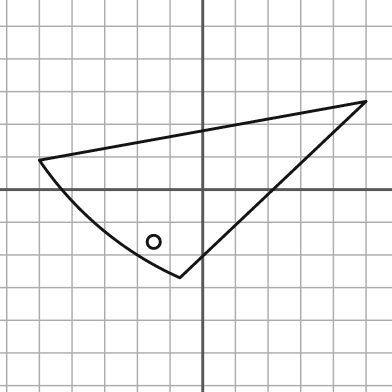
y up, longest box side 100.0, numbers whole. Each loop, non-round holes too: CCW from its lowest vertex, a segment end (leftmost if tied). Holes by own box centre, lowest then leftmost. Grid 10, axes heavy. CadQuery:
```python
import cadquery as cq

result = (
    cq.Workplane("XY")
    .moveTo(-7.0, -27.0)
    .lineTo(50.0, 27.0)
    .lineTo(-50.0, 9.0)
    .threePointArc((-31.0, -12.0), (-7.0, -27.0))
    .close()
    .moveTo(-15.0, -16.0)
    .circle(2.0)
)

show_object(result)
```